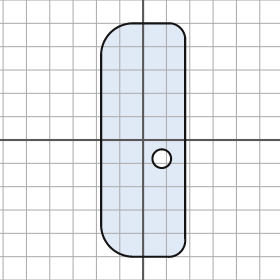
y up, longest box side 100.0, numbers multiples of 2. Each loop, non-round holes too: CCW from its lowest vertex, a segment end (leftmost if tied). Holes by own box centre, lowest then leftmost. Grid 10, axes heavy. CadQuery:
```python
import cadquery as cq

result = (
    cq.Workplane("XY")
    .moveTo(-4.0, -50.0)
    .lineTo(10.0, -50.0)
    .threePointArc((16.0, -48.0), (18.0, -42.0))
    .lineTo(18.0, 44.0)
    .threePointArc((16.0, 48.0), (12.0, 50.0))
    .lineTo(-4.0, 50.0)
    .threePointArc((-14.0, 46.0), (-18.0, 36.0))
    .lineTo(-18.0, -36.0)
    .threePointArc((-14.0, -46.0), (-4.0, -50.0))
    .close()
    .moveTo(8.0, -8.0)
    .circle(4.0)
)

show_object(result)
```